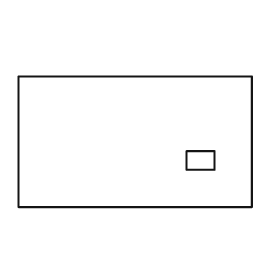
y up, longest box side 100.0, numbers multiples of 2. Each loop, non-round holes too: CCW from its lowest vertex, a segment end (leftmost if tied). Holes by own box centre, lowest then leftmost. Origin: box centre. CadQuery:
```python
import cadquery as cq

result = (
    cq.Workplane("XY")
    .moveTo(-50.0, -28.0)
    .lineTo(50.0, -28.0)
    .lineTo(50.0, 28.0)
    .lineTo(-50.0, 28.0)
    .close()
    .moveTo(22.0, -12.0)
    .lineTo(34.0, -12.0)
    .lineTo(34.0, -4.0)
    .lineTo(22.0, -4.0)
    .close()
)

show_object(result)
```